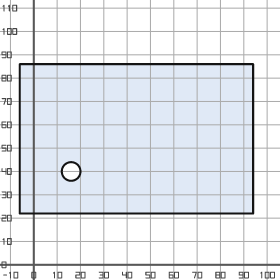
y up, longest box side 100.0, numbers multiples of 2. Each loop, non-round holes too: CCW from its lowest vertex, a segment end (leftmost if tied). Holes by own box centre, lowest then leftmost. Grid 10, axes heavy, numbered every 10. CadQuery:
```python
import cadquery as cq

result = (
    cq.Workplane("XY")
    .moveTo(-6.0, 22.0)
    .lineTo(94.0, 22.0)
    .lineTo(94.0, 86.0)
    .lineTo(-6.0, 86.0)
    .close()
    .moveTo(16.0, 40.0)
    .circle(4.0)
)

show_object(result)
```